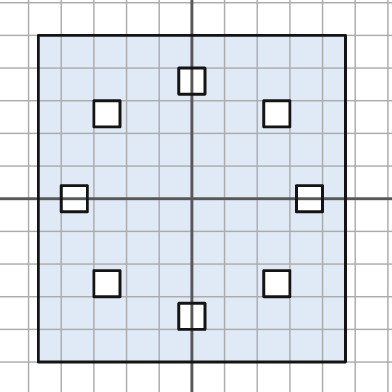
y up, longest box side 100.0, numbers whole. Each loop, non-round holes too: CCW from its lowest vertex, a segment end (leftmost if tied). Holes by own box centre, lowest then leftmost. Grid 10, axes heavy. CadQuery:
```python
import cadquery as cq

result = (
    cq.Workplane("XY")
    .moveTo(-47.0, -50.0)
    .lineTo(47.0, -50.0)
    .lineTo(47.0, 50.0)
    .lineTo(-47.0, 50.0)
    .close()
    .moveTo(-4.0, -40.0)
    .lineTo(4.0, -40.0)
    .lineTo(4.0, -32.0)
    .lineTo(-4.0, -32.0)
    .close()
    .moveTo(-30.0, -30.0)
    .lineTo(-22.0, -30.0)
    .lineTo(-22.0, -22.0)
    .lineTo(-30.0, -22.0)
    .close()
    .moveTo(22.0, -30.0)
    .lineTo(30.0, -30.0)
    .lineTo(30.0, -22.0)
    .lineTo(22.0, -22.0)
    .close()
    .moveTo(-40.0, -4.0)
    .lineTo(-32.0, -4.0)
    .lineTo(-32.0, 4.0)
    .lineTo(-40.0, 4.0)
    .close()
    .moveTo(32.0, -4.0)
    .lineTo(40.0, -4.0)
    .lineTo(40.0, 4.0)
    .lineTo(32.0, 4.0)
    .close()
    .moveTo(-30.0, 22.0)
    .lineTo(-22.0, 22.0)
    .lineTo(-22.0, 30.0)
    .lineTo(-30.0, 30.0)
    .close()
    .moveTo(22.0, 22.0)
    .lineTo(30.0, 22.0)
    .lineTo(30.0, 30.0)
    .lineTo(22.0, 30.0)
    .close()
    .moveTo(-4.0, 32.0)
    .lineTo(4.0, 32.0)
    .lineTo(4.0, 40.0)
    .lineTo(-4.0, 40.0)
    .close()
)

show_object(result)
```